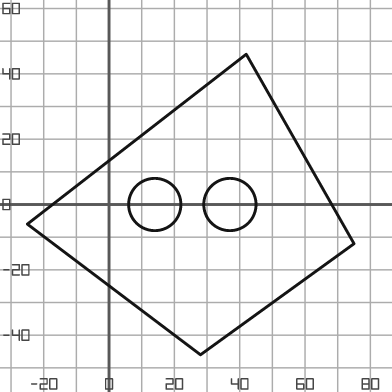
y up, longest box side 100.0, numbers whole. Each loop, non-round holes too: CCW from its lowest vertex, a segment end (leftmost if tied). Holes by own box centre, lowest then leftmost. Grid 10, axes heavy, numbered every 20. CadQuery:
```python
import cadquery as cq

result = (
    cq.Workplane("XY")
    .moveTo(28.0, -46.0)
    .lineTo(75.0, -12.0)
    .lineTo(42.0, 46.0)
    .lineTo(-25.0, -6.0)
    .close()
    .moveTo(14.0, 0.0)
    .circle(8.0)
    .moveTo(37.0, 0.0)
    .circle(8.0)
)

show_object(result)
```